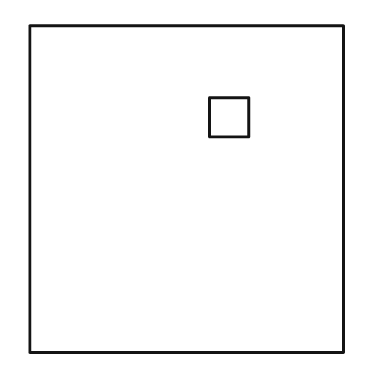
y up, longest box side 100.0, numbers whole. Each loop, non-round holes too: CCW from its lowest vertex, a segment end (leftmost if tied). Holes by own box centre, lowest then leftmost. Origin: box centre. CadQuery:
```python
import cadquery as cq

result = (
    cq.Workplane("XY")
    .moveTo(-48.0, -50.0)
    .lineTo(48.0, -50.0)
    .lineTo(48.0, 50.0)
    .lineTo(-48.0, 50.0)
    .close()
    .moveTo(7.0, 16.0)
    .lineTo(19.0, 16.0)
    .lineTo(19.0, 28.0)
    .lineTo(7.0, 28.0)
    .close()
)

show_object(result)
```